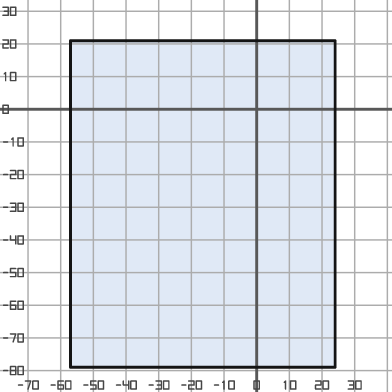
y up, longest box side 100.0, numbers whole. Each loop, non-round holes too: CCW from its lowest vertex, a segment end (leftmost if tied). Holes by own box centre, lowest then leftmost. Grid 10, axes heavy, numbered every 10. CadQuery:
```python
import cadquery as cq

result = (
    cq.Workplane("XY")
    .moveTo(-57.0, -79.0)
    .lineTo(24.0, -79.0)
    .lineTo(24.0, 21.0)
    .lineTo(-57.0, 21.0)
    .close()
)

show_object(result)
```